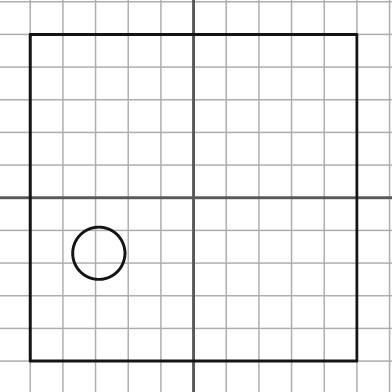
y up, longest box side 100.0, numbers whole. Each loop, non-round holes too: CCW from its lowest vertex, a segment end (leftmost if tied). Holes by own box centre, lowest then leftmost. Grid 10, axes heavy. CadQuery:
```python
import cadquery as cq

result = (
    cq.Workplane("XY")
    .moveTo(-50.0, -50.0)
    .lineTo(50.0, -50.0)
    .lineTo(50.0, 50.0)
    .lineTo(-50.0, 50.0)
    .close()
    .moveTo(-29.0, -17.0)
    .circle(8.0)
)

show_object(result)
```